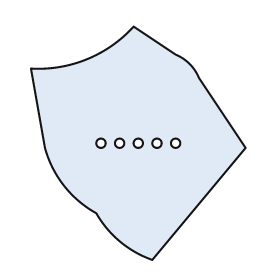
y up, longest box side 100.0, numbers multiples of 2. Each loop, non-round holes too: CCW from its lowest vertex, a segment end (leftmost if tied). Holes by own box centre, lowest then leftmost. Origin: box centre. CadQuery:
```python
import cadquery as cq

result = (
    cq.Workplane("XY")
    .moveTo(6.0, -50.0)
    .lineTo(46.0, -2.0)
    .lineTo(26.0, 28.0)
    .threePointArc((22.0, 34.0), (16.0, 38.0))
    .lineTo(-2.0, 50.0)
    .threePointArc((-22.0, 36.0), (-46.0, 32.0))
    .lineTo(-40.0, -2.0)
    .threePointArc((-32.0, -18.0), (-18.0, -30.0))
    .threePointArc((-8.0, -42.0), (6.0, -50.0))
    .close()
    .moveTo(-16.0, 0.0)
    .circle(2.0)
    .moveTo(-8.0, 0.0)
    .circle(2.0)
    .moveTo(0.0, 0.0)
    .circle(2.0)
    .moveTo(8.0, 0.0)
    .circle(2.0)
    .moveTo(16.0, 0.0)
    .circle(2.0)
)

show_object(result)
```